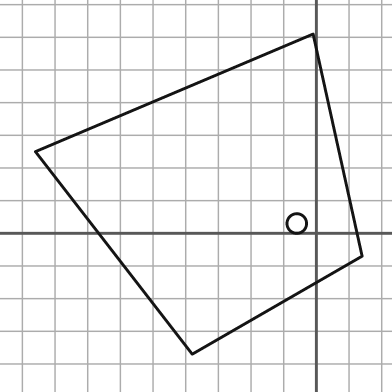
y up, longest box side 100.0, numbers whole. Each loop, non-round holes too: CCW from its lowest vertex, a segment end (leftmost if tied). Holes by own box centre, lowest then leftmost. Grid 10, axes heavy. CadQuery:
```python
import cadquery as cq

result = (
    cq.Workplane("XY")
    .moveTo(-38.0, -37.0)
    .lineTo(14.0, -7.0)
    .lineTo(-1.0, 61.0)
    .lineTo(-86.0, 25.0)
    .close()
    .moveTo(-6.0, 3.0)
    .circle(3.0)
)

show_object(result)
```